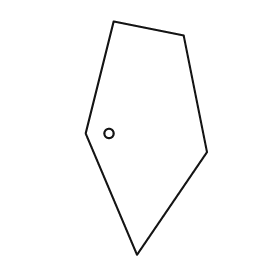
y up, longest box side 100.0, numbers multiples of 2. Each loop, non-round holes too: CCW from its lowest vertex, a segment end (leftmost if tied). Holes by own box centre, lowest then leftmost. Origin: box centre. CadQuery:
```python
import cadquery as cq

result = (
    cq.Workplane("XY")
    .moveTo(-4.0, -50.0)
    .lineTo(26.0, -6.0)
    .lineTo(16.0, 44.0)
    .lineTo(-14.0, 50.0)
    .lineTo(-26.0, 2.0)
    .close()
    .moveTo(-16.0, 2.0)
    .circle(2.0)
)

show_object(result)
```